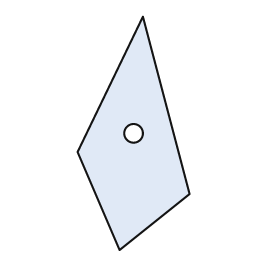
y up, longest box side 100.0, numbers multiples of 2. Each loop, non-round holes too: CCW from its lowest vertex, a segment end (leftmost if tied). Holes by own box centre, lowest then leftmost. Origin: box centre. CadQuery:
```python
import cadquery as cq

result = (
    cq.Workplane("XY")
    .moveTo(-6.0, -50.0)
    .lineTo(24.0, -26.0)
    .lineTo(4.0, 50.0)
    .lineTo(-24.0, -8.0)
    .close()
    .moveTo(0.0, 0.0)
    .circle(4.0)
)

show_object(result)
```